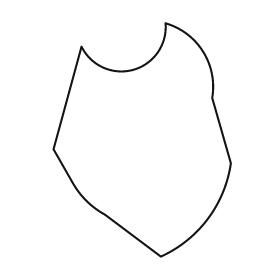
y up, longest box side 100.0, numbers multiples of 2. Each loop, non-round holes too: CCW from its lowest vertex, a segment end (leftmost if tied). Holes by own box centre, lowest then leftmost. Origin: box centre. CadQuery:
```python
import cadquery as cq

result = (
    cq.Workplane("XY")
    .moveTo(8.0, -50.0)
    .threePointArc((28.0, -34.0), (38.0, -10.0))
    .lineTo(30.0, 18.0)
    .threePointArc((26.0, 38.0), (10.0, 50.0))
    .threePointArc((-4.0, 30.0), (-26.0, 40.0))
    .lineTo(-38.0, -4.0)
    .lineTo(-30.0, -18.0)
    .threePointArc((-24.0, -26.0), (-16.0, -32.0))
    .close()
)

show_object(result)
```